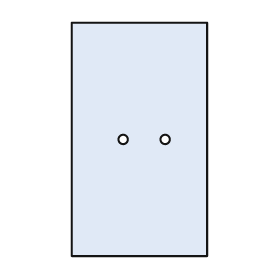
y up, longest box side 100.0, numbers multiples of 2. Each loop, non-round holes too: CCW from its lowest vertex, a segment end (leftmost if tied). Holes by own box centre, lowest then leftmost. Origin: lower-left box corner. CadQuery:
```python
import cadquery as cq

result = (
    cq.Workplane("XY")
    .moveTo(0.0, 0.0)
    .lineTo(58.0, 0.0)
    .lineTo(58.0, 100.0)
    .lineTo(0.0, 100.0)
    .close()
    .moveTo(22.0, 50.0)
    .circle(2.0)
    .moveTo(40.0, 50.0)
    .circle(2.0)
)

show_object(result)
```